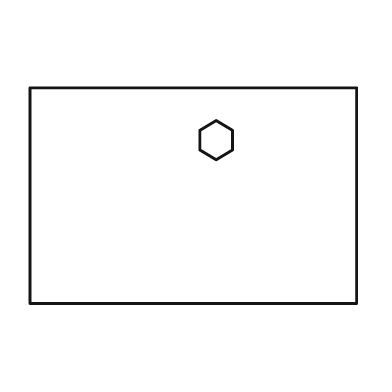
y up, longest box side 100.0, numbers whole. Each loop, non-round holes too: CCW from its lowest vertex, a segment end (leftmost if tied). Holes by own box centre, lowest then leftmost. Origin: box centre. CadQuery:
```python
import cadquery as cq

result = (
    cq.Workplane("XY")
    .moveTo(-50.0, -33.0)
    .lineTo(50.0, -33.0)
    .lineTo(50.0, 33.0)
    .lineTo(-50.0, 33.0)
    .close()
    .moveTo(7.0, 11.0)
    .lineTo(12.0, 14.0)
    .lineTo(12.0, 20.0)
    .lineTo(7.0, 23.0)
    .lineTo(2.0, 20.0)
    .lineTo(2.0, 14.0)
    .close()
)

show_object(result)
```